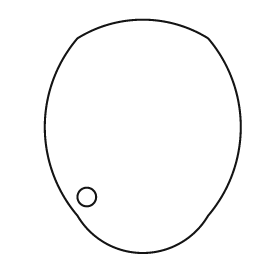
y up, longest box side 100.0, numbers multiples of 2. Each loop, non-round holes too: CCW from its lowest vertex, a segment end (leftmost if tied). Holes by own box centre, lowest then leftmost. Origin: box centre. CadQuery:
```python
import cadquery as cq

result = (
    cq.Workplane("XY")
    .moveTo(-28.0, -34.0)
    .threePointArc((0.0, -50.0), (28.0, -34.0))
    .threePointArc((42.0, 4.0), (28.0, 42.0))
    .threePointArc((0.0, 50.0), (-28.0, 42.0))
    .threePointArc((-42.0, 4.0), (-28.0, -34.0))
    .close()
    .moveTo(-24.0, -26.0)
    .circle(4.0)
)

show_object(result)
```